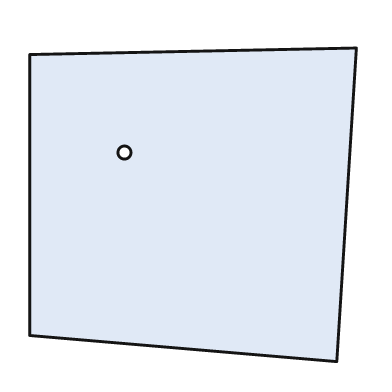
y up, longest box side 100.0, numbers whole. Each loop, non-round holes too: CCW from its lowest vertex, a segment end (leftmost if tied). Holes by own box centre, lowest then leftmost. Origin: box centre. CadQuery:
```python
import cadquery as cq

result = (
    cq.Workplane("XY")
    .moveTo(44.0, -48.0)
    .lineTo(50.0, 48.0)
    .lineTo(-50.0, 46.0)
    .lineTo(-50.0, -40.0)
    .close()
    .moveTo(-21.0, 16.0)
    .circle(2.0)
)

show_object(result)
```